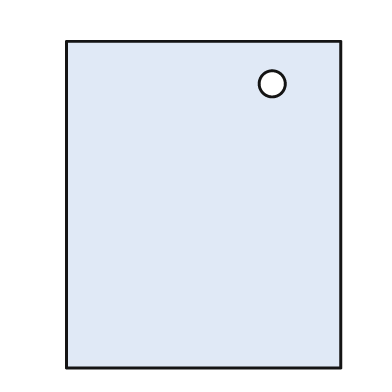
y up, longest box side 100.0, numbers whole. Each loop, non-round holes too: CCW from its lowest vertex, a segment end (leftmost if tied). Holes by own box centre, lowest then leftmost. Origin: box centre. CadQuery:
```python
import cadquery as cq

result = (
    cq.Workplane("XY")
    .moveTo(-42.0, -50.0)
    .lineTo(42.0, -50.0)
    .lineTo(42.0, 50.0)
    .lineTo(-42.0, 50.0)
    .close()
    .moveTo(21.0, 37.0)
    .circle(4.0)
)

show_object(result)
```